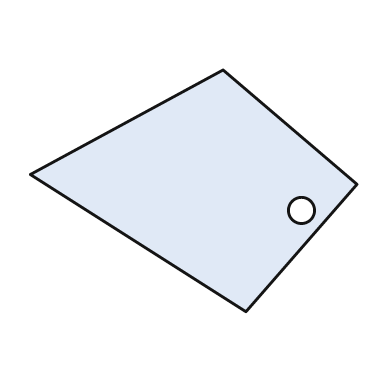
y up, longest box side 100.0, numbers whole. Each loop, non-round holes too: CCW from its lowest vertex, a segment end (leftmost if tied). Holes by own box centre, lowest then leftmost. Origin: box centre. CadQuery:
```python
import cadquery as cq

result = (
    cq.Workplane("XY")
    .moveTo(16.0, -37.0)
    .lineTo(50.0, 2.0)
    .lineTo(9.0, 37.0)
    .lineTo(-50.0, 5.0)
    .close()
    .moveTo(33.0, -6.0)
    .circle(4.0)
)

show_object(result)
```